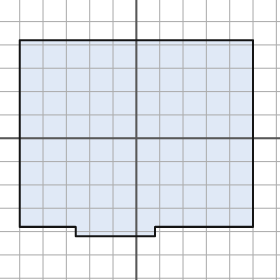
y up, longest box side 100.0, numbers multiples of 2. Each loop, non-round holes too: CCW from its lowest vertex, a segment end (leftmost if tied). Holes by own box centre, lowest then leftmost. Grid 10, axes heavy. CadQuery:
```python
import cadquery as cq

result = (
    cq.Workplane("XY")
    .moveTo(-26.0, -42.0)
    .lineTo(8.0, -42.0)
    .lineTo(8.0, -38.0)
    .lineTo(50.0, -38.0)
    .lineTo(50.0, 42.0)
    .lineTo(-50.0, 42.0)
    .lineTo(-50.0, -38.0)
    .lineTo(-26.0, -38.0)
    .close()
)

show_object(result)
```